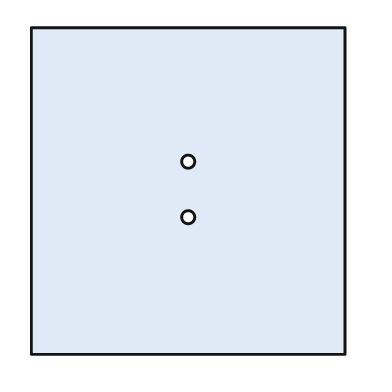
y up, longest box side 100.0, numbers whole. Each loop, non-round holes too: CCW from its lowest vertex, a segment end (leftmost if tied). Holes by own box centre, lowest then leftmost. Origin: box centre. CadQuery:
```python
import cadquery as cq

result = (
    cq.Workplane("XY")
    .moveTo(-48.0, -50.0)
    .lineTo(48.0, -50.0)
    .lineTo(48.0, 50.0)
    .lineTo(-48.0, 50.0)
    .close()
    .moveTo(0.0, -8.0)
    .circle(2.0)
    .moveTo(0.0, 9.0)
    .circle(2.0)
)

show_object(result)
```